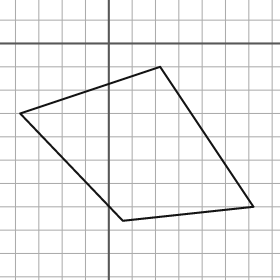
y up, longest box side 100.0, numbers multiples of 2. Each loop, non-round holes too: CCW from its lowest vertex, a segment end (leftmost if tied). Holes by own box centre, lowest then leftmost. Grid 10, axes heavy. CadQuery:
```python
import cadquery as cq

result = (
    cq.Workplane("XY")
    .moveTo(6.0, -76.0)
    .lineTo(62.0, -70.0)
    .lineTo(22.0, -10.0)
    .lineTo(-38.0, -30.0)
    .close()
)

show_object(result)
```